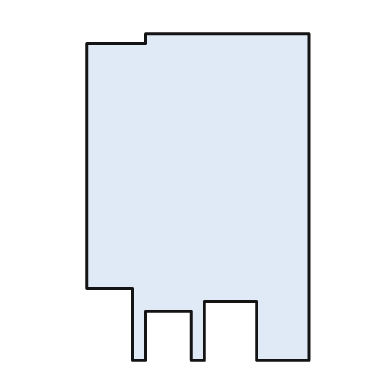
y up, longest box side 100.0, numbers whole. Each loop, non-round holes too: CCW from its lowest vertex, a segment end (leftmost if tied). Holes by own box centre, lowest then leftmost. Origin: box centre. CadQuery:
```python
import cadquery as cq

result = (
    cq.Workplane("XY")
    .moveTo(-20.0, -50.0)
    .lineTo(-16.0, -50.0)
    .lineTo(-16.0, -35.0)
    .lineTo(-2.0, -35.0)
    .lineTo(-2.0, -50.0)
    .lineTo(2.0, -50.0)
    .lineTo(2.0, -32.0)
    .lineTo(18.0, -32.0)
    .lineTo(18.0, -50.0)
    .lineTo(34.0, -50.0)
    .lineTo(34.0, 50.0)
    .lineTo(-16.0, 50.0)
    .lineTo(-16.0, 47.0)
    .lineTo(-34.0, 47.0)
    .lineTo(-34.0, -28.0)
    .lineTo(-20.0, -28.0)
    .close()
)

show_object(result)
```